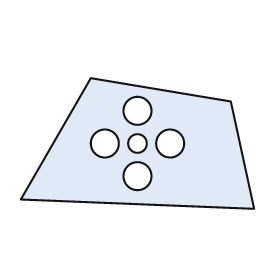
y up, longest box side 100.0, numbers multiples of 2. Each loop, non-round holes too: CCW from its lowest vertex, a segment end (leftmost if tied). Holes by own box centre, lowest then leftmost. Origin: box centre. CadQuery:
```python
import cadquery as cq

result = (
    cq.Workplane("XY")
    .moveTo(50.0, -28.0)
    .lineTo(40.0, 18.0)
    .lineTo(-20.0, 28.0)
    .lineTo(-50.0, -24.0)
    .close()
    .moveTo(0.0, -14.0)
    .circle(6.0)
    .moveTo(-14.0, 0.0)
    .circle(6.0)
    .moveTo(0.0, 0.0)
    .circle(4.0)
    .moveTo(14.0, 0.0)
    .circle(6.0)
    .moveTo(0.0, 14.0)
    .circle(6.0)
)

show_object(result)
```